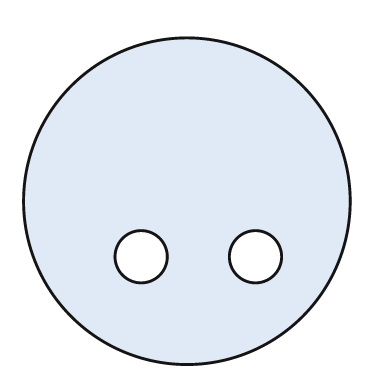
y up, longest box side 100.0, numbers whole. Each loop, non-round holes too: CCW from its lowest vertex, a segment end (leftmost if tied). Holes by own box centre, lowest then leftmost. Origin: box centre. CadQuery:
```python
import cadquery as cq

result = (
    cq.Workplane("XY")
    .moveTo(0.0, 0.0)
    .circle(50.0)
    .moveTo(-14.0, -17.0)
    .circle(8.0)
    .moveTo(21.0, -17.0)
    .circle(8.0)
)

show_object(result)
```